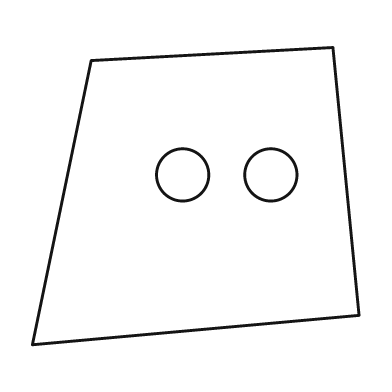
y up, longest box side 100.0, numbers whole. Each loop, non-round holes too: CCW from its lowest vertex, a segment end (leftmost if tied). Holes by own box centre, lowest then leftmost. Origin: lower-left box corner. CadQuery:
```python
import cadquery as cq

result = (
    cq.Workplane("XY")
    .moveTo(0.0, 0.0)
    .lineTo(100.0, 9.0)
    .lineTo(92.0, 91.0)
    .lineTo(18.0, 87.0)
    .close()
    .moveTo(46.0, 52.0)
    .circle(8.0)
    .moveTo(73.0, 52.0)
    .circle(8.0)
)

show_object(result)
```